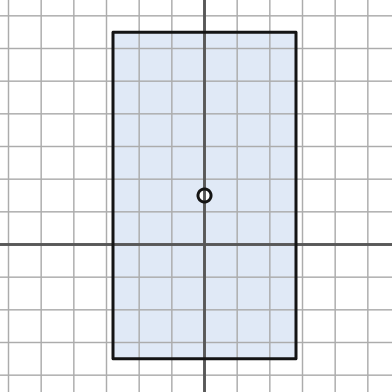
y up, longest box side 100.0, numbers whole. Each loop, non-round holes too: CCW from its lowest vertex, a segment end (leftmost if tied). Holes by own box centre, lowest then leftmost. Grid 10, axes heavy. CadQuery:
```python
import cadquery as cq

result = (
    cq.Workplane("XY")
    .moveTo(-28.0, -35.0)
    .lineTo(28.0, -35.0)
    .lineTo(28.0, 65.0)
    .lineTo(-28.0, 65.0)
    .close()
    .moveTo(0.0, 15.0)
    .circle(2.0)
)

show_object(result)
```